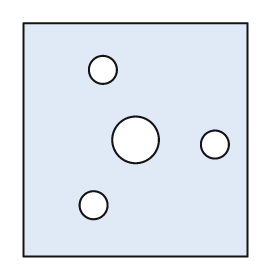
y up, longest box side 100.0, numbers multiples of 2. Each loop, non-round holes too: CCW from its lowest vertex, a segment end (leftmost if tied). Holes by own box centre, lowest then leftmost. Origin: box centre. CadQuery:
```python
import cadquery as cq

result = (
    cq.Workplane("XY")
    .moveTo(-48.0, -50.0)
    .lineTo(48.0, -50.0)
    .lineTo(48.0, 50.0)
    .lineTo(-48.0, 50.0)
    .close()
    .moveTo(-18.0, -28.0)
    .circle(6.0)
    .moveTo(34.0, -2.0)
    .circle(6.0)
    .moveTo(0.0, 0.0)
    .circle(10.0)
    .moveTo(-14.0, 30.0)
    .circle(6.0)
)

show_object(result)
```